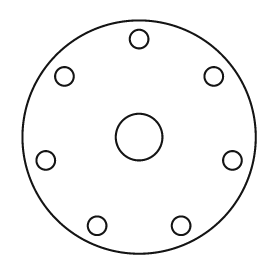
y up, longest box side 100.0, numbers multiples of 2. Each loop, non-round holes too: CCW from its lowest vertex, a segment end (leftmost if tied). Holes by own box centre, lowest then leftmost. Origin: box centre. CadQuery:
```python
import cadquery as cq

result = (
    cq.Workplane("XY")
    .moveTo(0.0, 0.0)
    .circle(50.0)
    .moveTo(-18.0, -38.0)
    .circle(4.0)
    .moveTo(18.0, -38.0)
    .circle(4.0)
    .moveTo(-40.0, -10.0)
    .circle(4.0)
    .moveTo(40.0, -10.0)
    .circle(4.0)
    .moveTo(0.0, 0.0)
    .circle(10.0)
    .moveTo(-32.0, 26.0)
    .circle(4.0)
    .moveTo(32.0, 26.0)
    .circle(4.0)
    .moveTo(0.0, 42.0)
    .circle(4.0)
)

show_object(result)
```